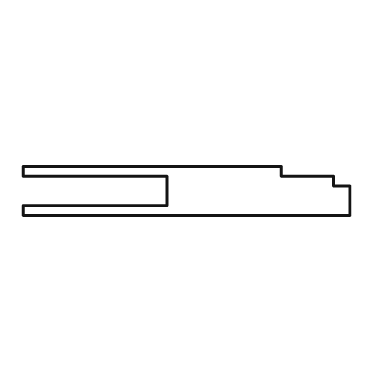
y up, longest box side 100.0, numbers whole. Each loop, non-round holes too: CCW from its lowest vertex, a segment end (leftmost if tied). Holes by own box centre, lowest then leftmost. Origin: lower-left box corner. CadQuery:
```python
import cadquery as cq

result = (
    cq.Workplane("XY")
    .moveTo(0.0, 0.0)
    .lineTo(100.0, 0.0)
    .lineTo(100.0, 9.0)
    .lineTo(95.0, 9.0)
    .lineTo(95.0, 12.0)
    .lineTo(79.0, 12.0)
    .lineTo(79.0, 15.0)
    .lineTo(0.0, 15.0)
    .lineTo(0.0, 12.0)
    .lineTo(44.0, 12.0)
    .lineTo(44.0, 3.0)
    .lineTo(0.0, 3.0)
    .close()
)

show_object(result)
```